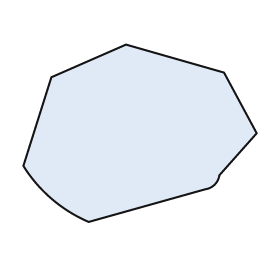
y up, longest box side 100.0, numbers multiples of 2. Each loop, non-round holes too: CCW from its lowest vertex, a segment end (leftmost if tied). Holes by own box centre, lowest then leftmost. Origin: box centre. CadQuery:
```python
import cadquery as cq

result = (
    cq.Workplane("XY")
    .moveTo(-22.0, -38.0)
    .lineTo(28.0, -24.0)
    .threePointArc((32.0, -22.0), (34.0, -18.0))
    .lineTo(50.0, 0.0)
    .lineTo(36.0, 26.0)
    .lineTo(-6.0, 38.0)
    .lineTo(-38.0, 24.0)
    .lineTo(-50.0, -14.0)
    .threePointArc((-38.0, -28.0), (-22.0, -38.0))
    .close()
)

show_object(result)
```